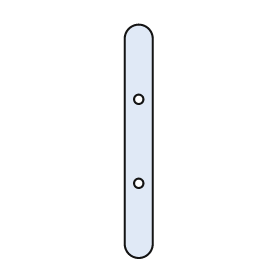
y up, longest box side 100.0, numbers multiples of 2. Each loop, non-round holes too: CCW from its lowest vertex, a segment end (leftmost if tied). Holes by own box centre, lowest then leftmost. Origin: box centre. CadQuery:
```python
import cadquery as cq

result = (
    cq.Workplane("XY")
    .moveTo(-6.0, -44.0)
    .threePointArc((0.0, -50.0), (6.0, -44.0))
    .lineTo(6.0, 44.0)
    .threePointArc((0.0, 50.0), (-6.0, 44.0))
    .close()
    .moveTo(0.0, -18.0)
    .circle(2.0)
    .moveTo(0.0, 18.0)
    .circle(2.0)
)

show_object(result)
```